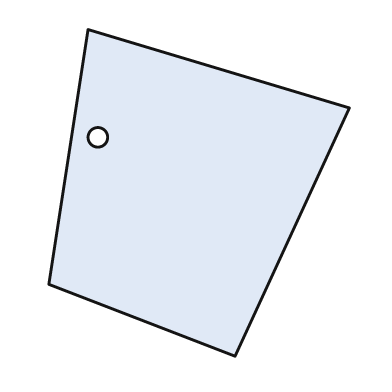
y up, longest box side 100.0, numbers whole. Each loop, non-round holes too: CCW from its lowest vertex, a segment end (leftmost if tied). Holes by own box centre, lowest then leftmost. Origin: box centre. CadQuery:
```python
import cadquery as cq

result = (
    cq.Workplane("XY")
    .moveTo(11.0, -50.0)
    .lineTo(46.0, 26.0)
    .lineTo(-34.0, 50.0)
    .lineTo(-46.0, -28.0)
    .close()
    .moveTo(-31.0, 17.0)
    .circle(3.0)
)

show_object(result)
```